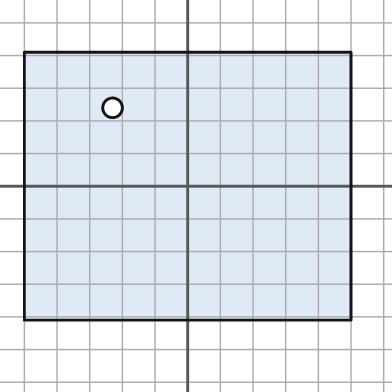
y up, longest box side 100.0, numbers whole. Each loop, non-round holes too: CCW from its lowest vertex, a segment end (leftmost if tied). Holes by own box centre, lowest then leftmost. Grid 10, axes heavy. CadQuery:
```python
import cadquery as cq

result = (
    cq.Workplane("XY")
    .moveTo(-50.0, -41.0)
    .lineTo(50.0, -41.0)
    .lineTo(50.0, 41.0)
    .lineTo(-50.0, 41.0)
    .close()
    .moveTo(-23.0, 24.0)
    .circle(3.0)
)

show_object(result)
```